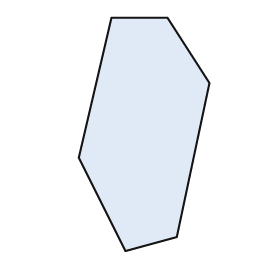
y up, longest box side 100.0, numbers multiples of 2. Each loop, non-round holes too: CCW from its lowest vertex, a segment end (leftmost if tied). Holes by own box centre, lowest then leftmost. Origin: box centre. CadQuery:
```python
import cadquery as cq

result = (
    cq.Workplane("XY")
    .moveTo(-8.0, -50.0)
    .lineTo(14.0, -44.0)
    .lineTo(28.0, 22.0)
    .lineTo(10.0, 50.0)
    .lineTo(-14.0, 50.0)
    .lineTo(-28.0, -10.0)
    .close()
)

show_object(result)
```